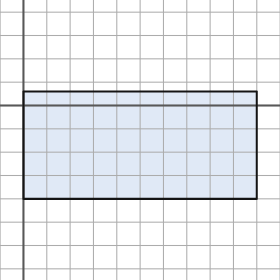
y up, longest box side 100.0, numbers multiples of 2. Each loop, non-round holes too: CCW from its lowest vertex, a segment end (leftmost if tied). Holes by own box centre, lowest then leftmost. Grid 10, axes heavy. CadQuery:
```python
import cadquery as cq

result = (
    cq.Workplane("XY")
    .moveTo(0.0, -40.0)
    .lineTo(100.0, -40.0)
    .lineTo(100.0, 6.0)
    .lineTo(0.0, 6.0)
    .close()
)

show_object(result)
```